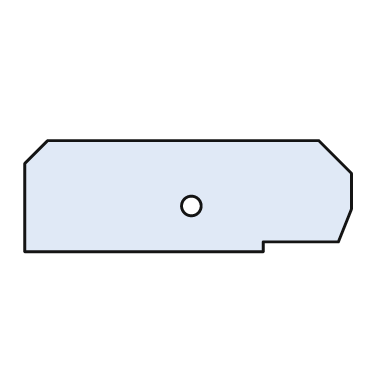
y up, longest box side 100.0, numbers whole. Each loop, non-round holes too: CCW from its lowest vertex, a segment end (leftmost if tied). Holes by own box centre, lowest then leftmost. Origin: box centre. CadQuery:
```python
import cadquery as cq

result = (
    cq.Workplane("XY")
    .moveTo(-50.0, -17.0)
    .lineTo(23.0, -17.0)
    .lineTo(23.0, -14.0)
    .lineTo(46.0, -14.0)
    .lineTo(50.0, -4.0)
    .lineTo(50.0, 7.0)
    .lineTo(40.0, 17.0)
    .lineTo(-43.0, 17.0)
    .lineTo(-50.0, 10.0)
    .close()
    .moveTo(1.0, -3.0)
    .circle(3.0)
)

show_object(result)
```